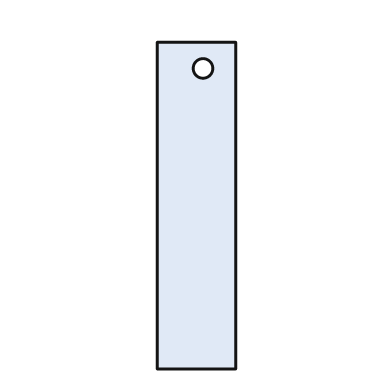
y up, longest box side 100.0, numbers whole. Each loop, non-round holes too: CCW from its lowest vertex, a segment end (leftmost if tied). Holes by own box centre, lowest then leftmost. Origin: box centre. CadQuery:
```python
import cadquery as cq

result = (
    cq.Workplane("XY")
    .moveTo(-12.0, -50.0)
    .lineTo(12.0, -50.0)
    .lineTo(12.0, 50.0)
    .lineTo(-12.0, 50.0)
    .close()
    .moveTo(2.0, 42.0)
    .circle(3.0)
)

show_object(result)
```